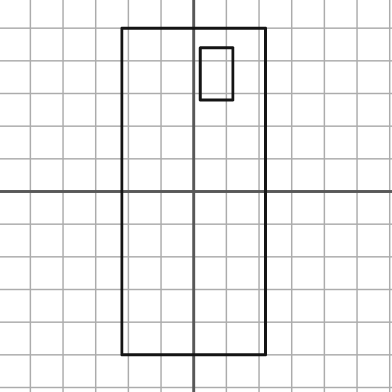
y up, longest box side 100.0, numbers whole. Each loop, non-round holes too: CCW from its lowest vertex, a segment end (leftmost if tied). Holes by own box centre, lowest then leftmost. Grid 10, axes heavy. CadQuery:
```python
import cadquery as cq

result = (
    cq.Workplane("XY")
    .moveTo(-22.0, -50.0)
    .lineTo(22.0, -50.0)
    .lineTo(22.0, 50.0)
    .lineTo(-22.0, 50.0)
    .close()
    .moveTo(2.0, 28.0)
    .lineTo(12.0, 28.0)
    .lineTo(12.0, 44.0)
    .lineTo(2.0, 44.0)
    .close()
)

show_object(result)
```